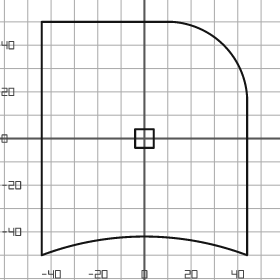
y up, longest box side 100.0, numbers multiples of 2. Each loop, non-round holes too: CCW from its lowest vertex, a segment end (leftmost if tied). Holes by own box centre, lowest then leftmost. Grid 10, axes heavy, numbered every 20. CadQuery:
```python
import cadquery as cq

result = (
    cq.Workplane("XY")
    .moveTo(-44.0, -50.0)
    .threePointArc((0.0, -42.0), (44.0, -50.0))
    .lineTo(44.0, 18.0)
    .threePointArc((34.0, 40.0), (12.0, 50.0))
    .lineTo(-44.0, 50.0)
    .close()
    .moveTo(-4.0, -4.0)
    .lineTo(4.0, -4.0)
    .lineTo(4.0, 4.0)
    .lineTo(-4.0, 4.0)
    .close()
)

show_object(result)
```